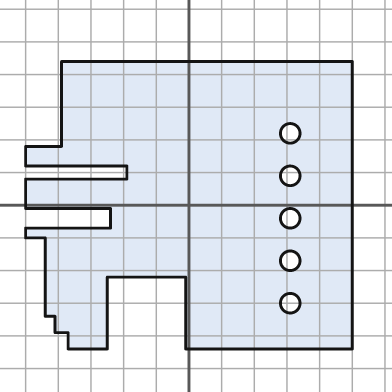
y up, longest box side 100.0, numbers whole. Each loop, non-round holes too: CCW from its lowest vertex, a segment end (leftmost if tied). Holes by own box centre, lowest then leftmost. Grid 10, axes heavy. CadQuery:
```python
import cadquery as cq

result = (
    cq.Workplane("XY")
    .moveTo(-37.0, -44.0)
    .lineTo(-25.0, -44.0)
    .lineTo(-25.0, -22.0)
    .lineTo(-1.0, -22.0)
    .lineTo(-1.0, -44.0)
    .lineTo(50.0, -44.0)
    .lineTo(50.0, 44.0)
    .lineTo(-39.0, 44.0)
    .lineTo(-39.0, 18.0)
    .lineTo(-50.0, 18.0)
    .lineTo(-50.0, 12.0)
    .lineTo(-19.0, 12.0)
    .lineTo(-19.0, 8.0)
    .lineTo(-50.0, 8.0)
    .lineTo(-50.0, -1.0)
    .lineTo(-24.0, -1.0)
    .lineTo(-24.0, -7.0)
    .lineTo(-50.0, -7.0)
    .lineTo(-50.0, -10.0)
    .lineTo(-44.0, -10.0)
    .lineTo(-44.0, -34.0)
    .lineTo(-41.0, -34.0)
    .lineTo(-41.0, -39.0)
    .lineTo(-37.0, -39.0)
    .close()
    .moveTo(31.0, -30.0)
    .circle(3.0)
    .moveTo(31.0, -17.0)
    .circle(3.0)
    .moveTo(31.0, -4.0)
    .circle(3.0)
    .moveTo(31.0, 9.0)
    .circle(3.0)
    .moveTo(31.0, 22.0)
    .circle(3.0)
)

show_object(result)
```